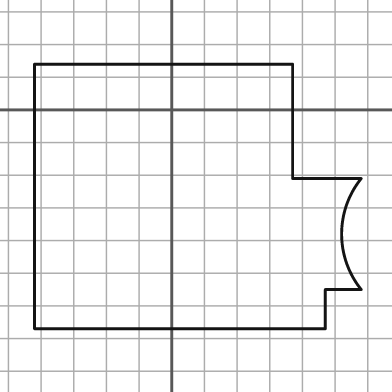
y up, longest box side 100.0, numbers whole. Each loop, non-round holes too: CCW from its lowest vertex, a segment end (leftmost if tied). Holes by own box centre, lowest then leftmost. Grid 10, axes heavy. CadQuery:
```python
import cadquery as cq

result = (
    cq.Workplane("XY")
    .moveTo(-42.0, -67.0)
    .lineTo(47.0, -67.0)
    .lineTo(47.0, -55.0)
    .lineTo(58.0, -55.0)
    .threePointArc((52.0, -38.0), (58.0, -21.0))
    .lineTo(37.0, -21.0)
    .lineTo(37.0, 14.0)
    .lineTo(-42.0, 14.0)
    .close()
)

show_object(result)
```